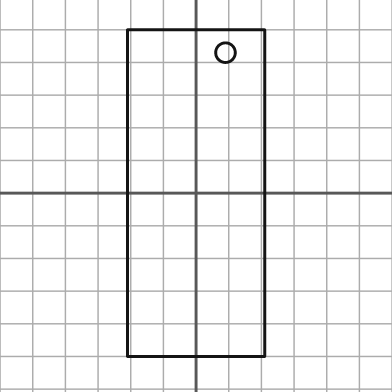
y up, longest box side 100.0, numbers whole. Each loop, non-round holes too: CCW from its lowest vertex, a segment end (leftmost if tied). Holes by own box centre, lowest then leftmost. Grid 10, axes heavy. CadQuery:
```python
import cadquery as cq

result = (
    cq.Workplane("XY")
    .moveTo(-21.0, -50.0)
    .lineTo(21.0, -50.0)
    .lineTo(21.0, 50.0)
    .lineTo(-21.0, 50.0)
    .close()
    .moveTo(9.0, 43.0)
    .circle(3.0)
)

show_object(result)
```